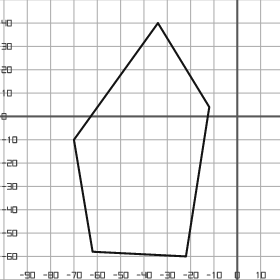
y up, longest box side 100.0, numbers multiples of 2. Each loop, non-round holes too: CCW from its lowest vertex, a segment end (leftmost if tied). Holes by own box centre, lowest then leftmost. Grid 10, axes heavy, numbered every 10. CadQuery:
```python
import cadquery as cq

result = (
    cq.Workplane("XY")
    .moveTo(-22.0, -60.0)
    .lineTo(-12.0, 4.0)
    .lineTo(-34.0, 40.0)
    .lineTo(-70.0, -10.0)
    .lineTo(-62.0, -58.0)
    .close()
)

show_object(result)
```